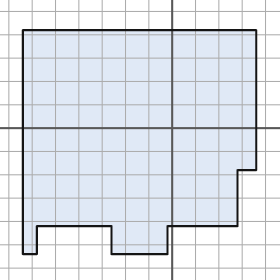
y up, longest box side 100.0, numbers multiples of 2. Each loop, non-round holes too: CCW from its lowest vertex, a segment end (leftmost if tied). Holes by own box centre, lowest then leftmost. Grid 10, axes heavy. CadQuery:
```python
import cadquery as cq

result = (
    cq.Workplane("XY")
    .moveTo(-64.0, -54.0)
    .lineTo(-58.0, -54.0)
    .lineTo(-58.0, -42.0)
    .lineTo(-26.0, -42.0)
    .lineTo(-26.0, -54.0)
    .lineTo(-2.0, -54.0)
    .lineTo(-2.0, -42.0)
    .lineTo(28.0, -42.0)
    .lineTo(28.0, -18.0)
    .lineTo(36.0, -18.0)
    .lineTo(36.0, 42.0)
    .lineTo(-64.0, 42.0)
    .close()
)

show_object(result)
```